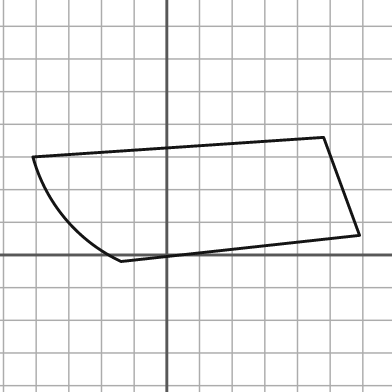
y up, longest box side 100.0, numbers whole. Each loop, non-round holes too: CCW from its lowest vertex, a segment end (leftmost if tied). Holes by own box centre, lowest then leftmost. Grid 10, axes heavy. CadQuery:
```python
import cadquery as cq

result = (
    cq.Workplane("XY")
    .moveTo(-14.0, -2.0)
    .lineTo(59.0, 6.0)
    .lineTo(48.0, 36.0)
    .lineTo(-41.0, 30.0)
    .threePointArc((-31.0, 11.0), (-14.0, -2.0))
    .close()
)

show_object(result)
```